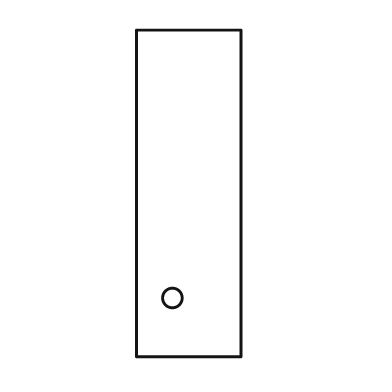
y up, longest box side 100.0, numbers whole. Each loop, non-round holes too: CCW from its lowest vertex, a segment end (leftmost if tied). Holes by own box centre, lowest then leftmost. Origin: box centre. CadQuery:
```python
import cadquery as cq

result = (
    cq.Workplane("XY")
    .moveTo(-16.0, -50.0)
    .lineTo(16.0, -50.0)
    .lineTo(16.0, 50.0)
    .lineTo(-16.0, 50.0)
    .close()
    .moveTo(-5.0, -32.0)
    .circle(3.0)
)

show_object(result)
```